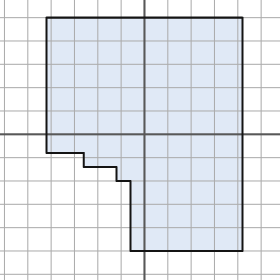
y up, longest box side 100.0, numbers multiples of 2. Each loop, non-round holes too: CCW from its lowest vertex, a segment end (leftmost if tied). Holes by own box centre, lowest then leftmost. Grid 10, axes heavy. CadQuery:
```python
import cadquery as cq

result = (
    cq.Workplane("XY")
    .moveTo(-6.0, -50.0)
    .lineTo(42.0, -50.0)
    .lineTo(42.0, 50.0)
    .lineTo(-42.0, 50.0)
    .lineTo(-42.0, -8.0)
    .lineTo(-26.0, -8.0)
    .lineTo(-26.0, -14.0)
    .lineTo(-12.0, -14.0)
    .lineTo(-12.0, -20.0)
    .lineTo(-6.0, -20.0)
    .close()
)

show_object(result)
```